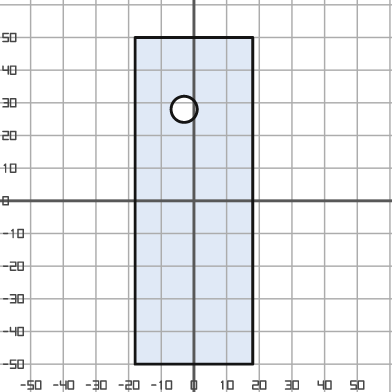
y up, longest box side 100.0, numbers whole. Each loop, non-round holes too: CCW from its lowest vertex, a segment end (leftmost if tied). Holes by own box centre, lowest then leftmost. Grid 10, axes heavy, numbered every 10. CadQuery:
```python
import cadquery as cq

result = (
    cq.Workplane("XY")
    .moveTo(-18.0, -50.0)
    .lineTo(18.0, -50.0)
    .lineTo(18.0, 50.0)
    .lineTo(-18.0, 50.0)
    .close()
    .moveTo(-3.0, 28.0)
    .circle(4.0)
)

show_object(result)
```